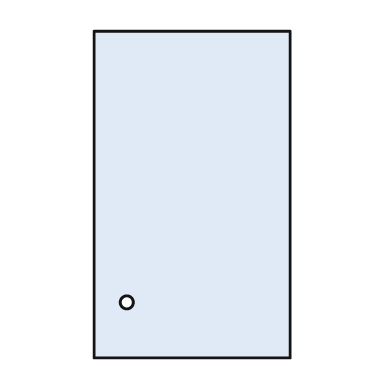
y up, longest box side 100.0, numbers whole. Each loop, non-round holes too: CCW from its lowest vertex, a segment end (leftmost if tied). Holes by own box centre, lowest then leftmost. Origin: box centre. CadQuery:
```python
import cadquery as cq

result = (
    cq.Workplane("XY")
    .moveTo(-30.0, -50.0)
    .lineTo(30.0, -50.0)
    .lineTo(30.0, 50.0)
    .lineTo(-30.0, 50.0)
    .close()
    .moveTo(-20.0, -33.0)
    .circle(2.0)
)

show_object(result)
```